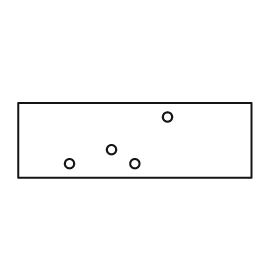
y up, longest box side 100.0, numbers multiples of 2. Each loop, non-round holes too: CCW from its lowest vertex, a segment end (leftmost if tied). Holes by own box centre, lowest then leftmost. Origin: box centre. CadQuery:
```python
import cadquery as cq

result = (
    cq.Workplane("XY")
    .moveTo(-50.0, -16.0)
    .lineTo(50.0, -16.0)
    .lineTo(50.0, 16.0)
    .lineTo(-50.0, 16.0)
    .close()
    .moveTo(-28.0, -10.0)
    .circle(2.0)
    .moveTo(0.0, -10.0)
    .circle(2.0)
    .moveTo(-10.0, -4.0)
    .circle(2.0)
    .moveTo(14.0, 10.0)
    .circle(2.0)
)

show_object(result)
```